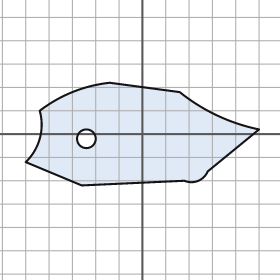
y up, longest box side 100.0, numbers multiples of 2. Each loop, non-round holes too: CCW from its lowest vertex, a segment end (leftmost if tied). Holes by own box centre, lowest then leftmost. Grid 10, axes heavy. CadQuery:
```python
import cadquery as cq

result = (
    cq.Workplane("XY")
    .moveTo(-26.0, -22.0)
    .lineTo(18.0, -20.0)
    .threePointArc((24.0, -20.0), (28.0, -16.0))
    .lineTo(50.0, 2.0)
    .threePointArc((32.0, 8.0), (16.0, 18.0))
    .lineTo(-14.0, 22.0)
    .threePointArc((-30.0, 18.0), (-44.0, 10.0))
    .threePointArc((-44.0, -2.0), (-50.0, -12.0))
    .close()
    .moveTo(-24.0, -2.0)
    .circle(4.0)
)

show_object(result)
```